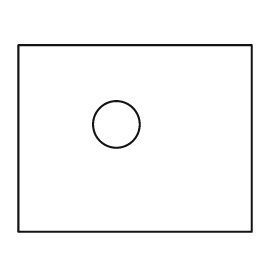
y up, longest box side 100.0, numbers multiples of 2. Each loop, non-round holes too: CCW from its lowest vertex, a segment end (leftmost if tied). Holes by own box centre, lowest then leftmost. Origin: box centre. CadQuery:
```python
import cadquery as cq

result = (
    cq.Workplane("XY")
    .moveTo(-50.0, -40.0)
    .lineTo(50.0, -40.0)
    .lineTo(50.0, 40.0)
    .lineTo(-50.0, 40.0)
    .close()
    .moveTo(-8.0, 6.0)
    .circle(10.0)
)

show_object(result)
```